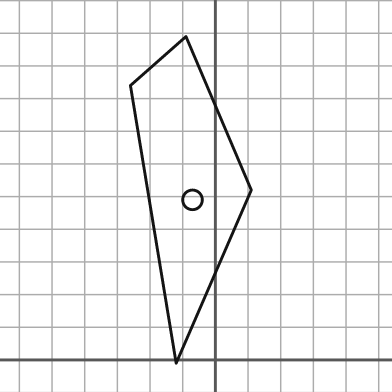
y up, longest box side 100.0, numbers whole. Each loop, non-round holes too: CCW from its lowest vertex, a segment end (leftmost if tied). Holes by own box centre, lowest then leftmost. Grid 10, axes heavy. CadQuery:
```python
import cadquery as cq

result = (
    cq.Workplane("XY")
    .moveTo(-12.0, -1.0)
    .lineTo(11.0, 52.0)
    .lineTo(-9.0, 99.0)
    .lineTo(-26.0, 84.0)
    .close()
    .moveTo(-7.0, 49.0)
    .circle(3.0)
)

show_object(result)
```